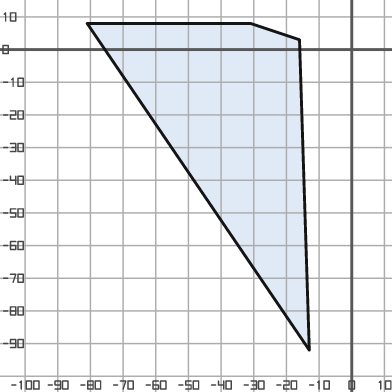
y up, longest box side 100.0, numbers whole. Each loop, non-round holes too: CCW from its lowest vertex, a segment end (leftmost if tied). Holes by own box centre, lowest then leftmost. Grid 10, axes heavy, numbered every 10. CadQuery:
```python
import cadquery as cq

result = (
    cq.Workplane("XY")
    .moveTo(-13.0, -92.0)
    .lineTo(-16.0, 3.0)
    .lineTo(-31.0, 8.0)
    .lineTo(-81.0, 8.0)
    .close()
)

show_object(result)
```